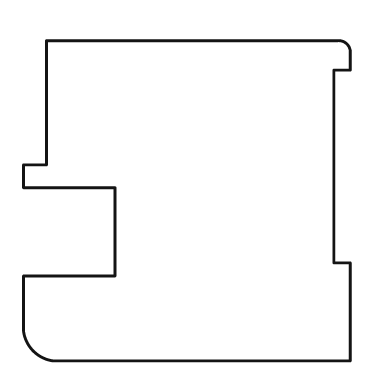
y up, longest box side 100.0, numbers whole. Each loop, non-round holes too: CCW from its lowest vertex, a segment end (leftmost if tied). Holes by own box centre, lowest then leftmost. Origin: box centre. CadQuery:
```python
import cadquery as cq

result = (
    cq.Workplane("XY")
    .moveTo(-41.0, -49.0)
    .lineTo(50.0, -49.0)
    .lineTo(50.0, -19.0)
    .lineTo(45.0, -19.0)
    .lineTo(45.0, 40.0)
    .lineTo(50.0, 40.0)
    .lineTo(50.0, 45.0)
    .threePointArc((49.0, 48.0), (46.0, 49.0))
    .lineTo(-43.0, 49.0)
    .lineTo(-43.0, 11.0)
    .lineTo(-50.0, 11.0)
    .lineTo(-50.0, 4.0)
    .lineTo(-22.0, 4.0)
    .lineTo(-22.0, -23.0)
    .lineTo(-50.0, -23.0)
    .lineTo(-50.0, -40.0)
    .threePointArc((-47.0, -46.0), (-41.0, -49.0))
    .close()
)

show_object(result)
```